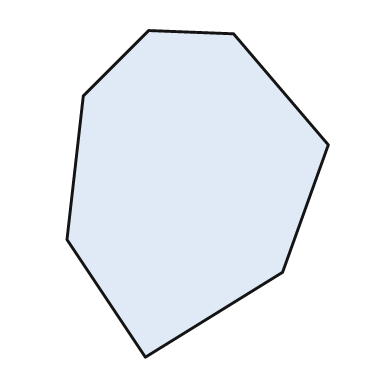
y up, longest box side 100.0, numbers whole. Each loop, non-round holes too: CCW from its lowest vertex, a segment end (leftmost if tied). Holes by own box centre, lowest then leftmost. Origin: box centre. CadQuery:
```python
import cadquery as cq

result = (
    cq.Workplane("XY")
    .moveTo(-16.0, -50.0)
    .lineTo(26.0, -24.0)
    .lineTo(40.0, 15.0)
    .lineTo(11.0, 49.0)
    .lineTo(-15.0, 50.0)
    .lineTo(-35.0, 30.0)
    .lineTo(-40.0, -14.0)
    .close()
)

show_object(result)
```